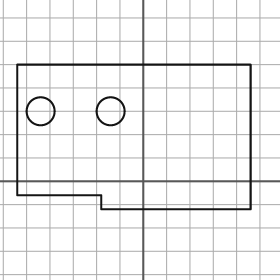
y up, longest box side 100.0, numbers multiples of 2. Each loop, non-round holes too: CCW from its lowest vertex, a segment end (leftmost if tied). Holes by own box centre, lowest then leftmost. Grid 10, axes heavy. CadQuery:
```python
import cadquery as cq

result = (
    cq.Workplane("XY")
    .moveTo(-18.0, -12.0)
    .lineTo(46.0, -12.0)
    .lineTo(46.0, 50.0)
    .lineTo(-54.0, 50.0)
    .lineTo(-54.0, -6.0)
    .lineTo(-18.0, -6.0)
    .close()
    .moveTo(-44.0, 30.0)
    .circle(6.0)
    .moveTo(-14.0, 30.0)
    .circle(6.0)
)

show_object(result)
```